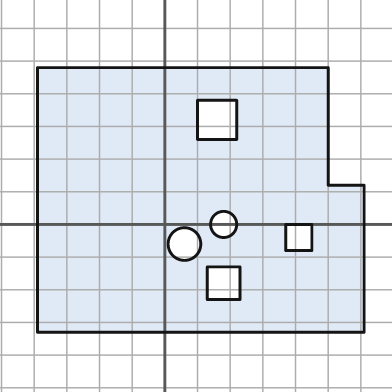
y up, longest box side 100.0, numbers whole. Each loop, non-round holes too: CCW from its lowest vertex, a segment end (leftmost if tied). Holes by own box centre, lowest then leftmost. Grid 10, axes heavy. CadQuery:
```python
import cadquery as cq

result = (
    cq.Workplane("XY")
    .moveTo(-39.0, -33.0)
    .lineTo(61.0, -33.0)
    .lineTo(61.0, 12.0)
    .lineTo(50.0, 12.0)
    .lineTo(50.0, 48.0)
    .lineTo(-39.0, 48.0)
    .close()
    .moveTo(13.0, -23.0)
    .lineTo(23.0, -23.0)
    .lineTo(23.0, -13.0)
    .lineTo(13.0, -13.0)
    .close()
    .moveTo(6.0, -6.0)
    .circle(5.0)
    .moveTo(37.0, -8.0)
    .lineTo(45.0, -8.0)
    .lineTo(45.0, 0.0)
    .lineTo(37.0, 0.0)
    .close()
    .moveTo(18.0, 0.0)
    .circle(4.0)
    .moveTo(10.0, 26.0)
    .lineTo(22.0, 26.0)
    .lineTo(22.0, 38.0)
    .lineTo(10.0, 38.0)
    .close()
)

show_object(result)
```